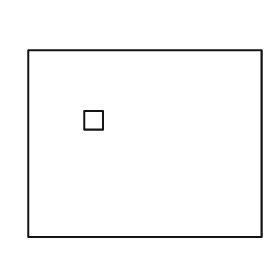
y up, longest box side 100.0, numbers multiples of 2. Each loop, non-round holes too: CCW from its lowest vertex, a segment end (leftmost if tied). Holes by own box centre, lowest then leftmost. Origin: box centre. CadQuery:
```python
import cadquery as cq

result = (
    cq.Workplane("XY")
    .moveTo(-50.0, -40.0)
    .lineTo(50.0, -40.0)
    .lineTo(50.0, 40.0)
    .lineTo(-50.0, 40.0)
    .close()
    .moveTo(-26.0, 6.0)
    .lineTo(-18.0, 6.0)
    .lineTo(-18.0, 14.0)
    .lineTo(-26.0, 14.0)
    .close()
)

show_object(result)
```